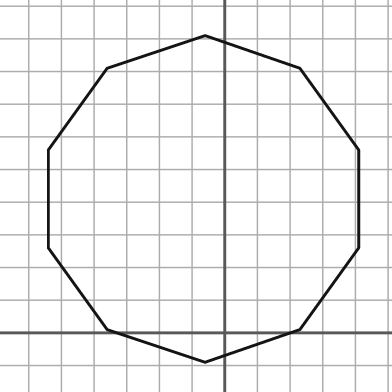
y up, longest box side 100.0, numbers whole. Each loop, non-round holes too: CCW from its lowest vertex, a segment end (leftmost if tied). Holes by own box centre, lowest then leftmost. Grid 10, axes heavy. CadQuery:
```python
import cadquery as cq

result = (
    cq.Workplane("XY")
    .moveTo(-6.0, -9.0)
    .lineTo(23.0, 1.0)
    .lineTo(41.0, 26.0)
    .lineTo(41.0, 56.0)
    .lineTo(23.0, 81.0)
    .lineTo(-6.0, 91.0)
    .lineTo(-36.0, 81.0)
    .lineTo(-54.0, 56.0)
    .lineTo(-54.0, 26.0)
    .lineTo(-36.0, 1.0)
    .close()
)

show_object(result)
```